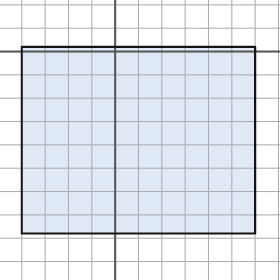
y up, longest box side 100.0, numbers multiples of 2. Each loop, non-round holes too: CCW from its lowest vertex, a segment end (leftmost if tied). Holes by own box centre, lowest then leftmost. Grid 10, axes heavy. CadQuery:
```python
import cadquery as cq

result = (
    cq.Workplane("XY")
    .moveTo(-40.0, -78.0)
    .lineTo(60.0, -78.0)
    .lineTo(60.0, 2.0)
    .lineTo(-40.0, 2.0)
    .close()
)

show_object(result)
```